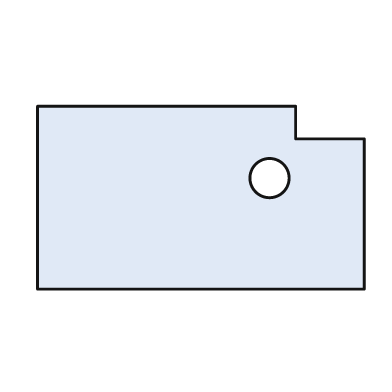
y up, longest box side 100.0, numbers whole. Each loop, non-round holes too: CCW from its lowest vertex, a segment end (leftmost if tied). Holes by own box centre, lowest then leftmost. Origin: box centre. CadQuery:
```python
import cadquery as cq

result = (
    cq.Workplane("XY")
    .moveTo(-50.0, -28.0)
    .lineTo(50.0, -28.0)
    .lineTo(50.0, 18.0)
    .lineTo(29.0, 18.0)
    .lineTo(29.0, 28.0)
    .lineTo(-50.0, 28.0)
    .close()
    .moveTo(21.0, 6.0)
    .circle(6.0)
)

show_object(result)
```